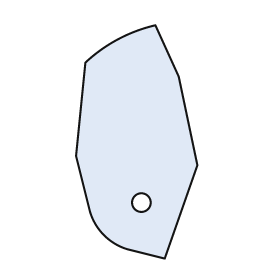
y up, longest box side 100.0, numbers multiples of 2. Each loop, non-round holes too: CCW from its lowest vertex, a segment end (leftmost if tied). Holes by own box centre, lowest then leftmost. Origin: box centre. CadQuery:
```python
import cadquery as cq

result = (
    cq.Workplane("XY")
    .moveTo(12.0, -50.0)
    .lineTo(26.0, -10.0)
    .lineTo(18.0, 28.0)
    .lineTo(8.0, 50.0)
    .threePointArc((-8.0, 44.0), (-22.0, 34.0))
    .lineTo(-26.0, -6.0)
    .lineTo(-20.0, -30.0)
    .threePointArc((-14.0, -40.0), (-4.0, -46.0))
    .close()
    .moveTo(2.0, -26.0)
    .circle(4.0)
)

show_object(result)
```